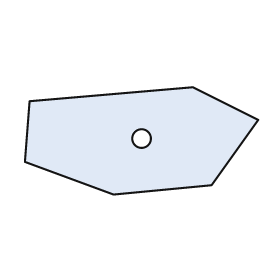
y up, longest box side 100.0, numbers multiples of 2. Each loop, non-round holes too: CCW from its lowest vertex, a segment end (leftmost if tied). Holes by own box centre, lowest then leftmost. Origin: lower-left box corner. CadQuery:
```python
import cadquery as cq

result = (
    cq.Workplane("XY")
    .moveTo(38.0, 0.0)
    .lineTo(80.0, 4.0)
    .lineTo(100.0, 32.0)
    .lineTo(72.0, 46.0)
    .lineTo(2.0, 40.0)
    .lineTo(0.0, 14.0)
    .close()
    .moveTo(50.0, 24.0)
    .circle(4.0)
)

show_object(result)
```